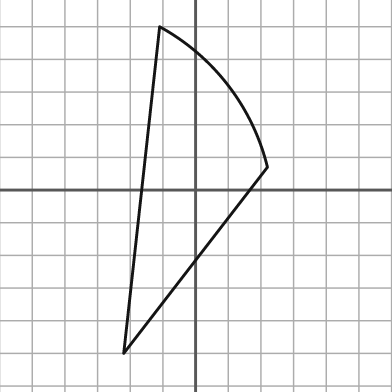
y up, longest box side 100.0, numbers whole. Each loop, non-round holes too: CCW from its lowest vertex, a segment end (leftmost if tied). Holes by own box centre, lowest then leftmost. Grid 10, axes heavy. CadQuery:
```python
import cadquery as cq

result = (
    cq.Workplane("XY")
    .moveTo(-22.0, -50.0)
    .lineTo(22.0, 7.0)
    .threePointArc((10.0, 32.0), (-11.0, 50.0))
    .close()
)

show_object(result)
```